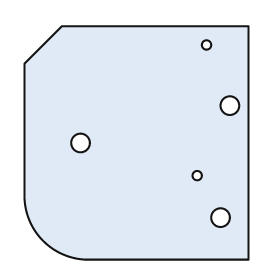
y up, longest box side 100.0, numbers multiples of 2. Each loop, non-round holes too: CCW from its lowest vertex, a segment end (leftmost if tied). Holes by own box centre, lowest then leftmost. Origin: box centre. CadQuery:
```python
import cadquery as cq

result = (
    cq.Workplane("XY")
    .moveTo(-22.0, -50.0)
    .lineTo(48.0, -50.0)
    .lineTo(48.0, 50.0)
    .lineTo(-32.0, 50.0)
    .lineTo(-48.0, 34.0)
    .lineTo(-48.0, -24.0)
    .threePointArc((-40.0, -42.0), (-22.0, -50.0))
    .close()
    .moveTo(36.0, -32.0)
    .circle(4.0)
    .moveTo(26.0, -14.0)
    .circle(2.0)
    .moveTo(-24.0, 0.0)
    .circle(4.0)
    .moveTo(40.0, 16.0)
    .circle(4.0)
    .moveTo(30.0, 42.0)
    .circle(2.0)
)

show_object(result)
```